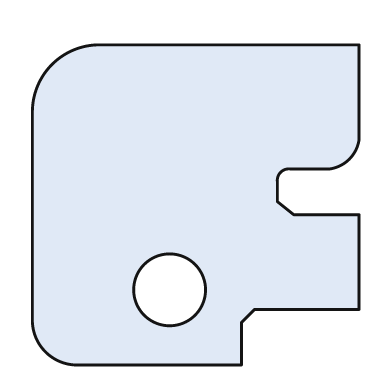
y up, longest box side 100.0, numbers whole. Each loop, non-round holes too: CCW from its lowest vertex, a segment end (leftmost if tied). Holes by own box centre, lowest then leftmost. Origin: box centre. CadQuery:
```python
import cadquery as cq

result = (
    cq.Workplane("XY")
    .moveTo(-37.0, -49.0)
    .lineTo(14.0, -49.0)
    .lineTo(14.0, -36.0)
    .lineTo(18.0, -32.0)
    .lineTo(50.0, -32.0)
    .lineTo(50.0, -3.0)
    .lineTo(30.0, -3.0)
    .lineTo(25.0, 1.0)
    .lineTo(25.0, 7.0)
    .threePointArc((26.0, 10.0), (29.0, 11.0))
    .lineTo(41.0, 11.0)
    .threePointArc((47.0, 14.0), (50.0, 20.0))
    .lineTo(50.0, 49.0)
    .lineTo(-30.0, 49.0)
    .threePointArc((-44.0, 43.0), (-50.0, 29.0))
    .lineTo(-50.0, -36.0)
    .threePointArc((-46.0, -45.0), (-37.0, -49.0))
    .close()
    .moveTo(-8.0, -26.0)
    .circle(11.0)
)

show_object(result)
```